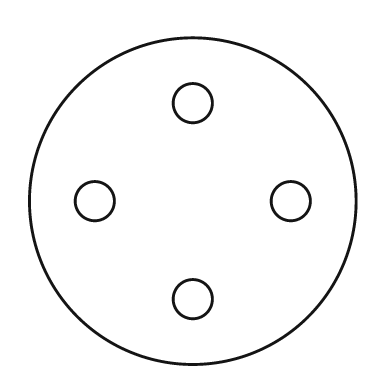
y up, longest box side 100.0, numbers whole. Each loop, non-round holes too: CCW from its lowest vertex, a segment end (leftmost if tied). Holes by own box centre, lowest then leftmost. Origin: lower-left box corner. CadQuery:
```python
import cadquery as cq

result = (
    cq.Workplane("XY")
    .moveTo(50.0, 50.0)
    .circle(50.0)
    .moveTo(50.0, 20.0)
    .circle(6.0)
    .moveTo(20.0, 50.0)
    .circle(6.0)
    .moveTo(80.0, 50.0)
    .circle(6.0)
    .moveTo(50.0, 80.0)
    .circle(6.0)
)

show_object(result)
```